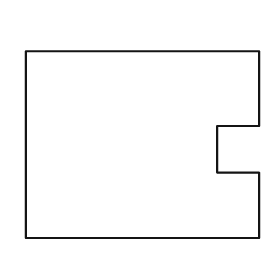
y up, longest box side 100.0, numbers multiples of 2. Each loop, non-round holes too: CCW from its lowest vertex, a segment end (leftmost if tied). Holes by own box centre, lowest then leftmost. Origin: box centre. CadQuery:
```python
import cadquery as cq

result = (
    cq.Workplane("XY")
    .moveTo(-50.0, -40.0)
    .lineTo(50.0, -40.0)
    .lineTo(50.0, -12.0)
    .lineTo(32.0, -12.0)
    .lineTo(32.0, 8.0)
    .lineTo(50.0, 8.0)
    .lineTo(50.0, 40.0)
    .lineTo(-50.0, 40.0)
    .close()
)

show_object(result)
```